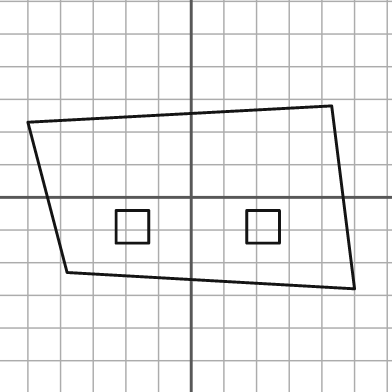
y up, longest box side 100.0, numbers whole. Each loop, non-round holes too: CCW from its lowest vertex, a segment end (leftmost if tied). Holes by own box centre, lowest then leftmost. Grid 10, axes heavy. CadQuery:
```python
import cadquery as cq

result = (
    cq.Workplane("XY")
    .moveTo(50.0, -28.0)
    .lineTo(43.0, 28.0)
    .lineTo(-50.0, 23.0)
    .lineTo(-38.0, -23.0)
    .close()
    .moveTo(-23.0, -14.0)
    .lineTo(-13.0, -14.0)
    .lineTo(-13.0, -4.0)
    .lineTo(-23.0, -4.0)
    .close()
    .moveTo(17.0, -14.0)
    .lineTo(27.0, -14.0)
    .lineTo(27.0, -4.0)
    .lineTo(17.0, -4.0)
    .close()
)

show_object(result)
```